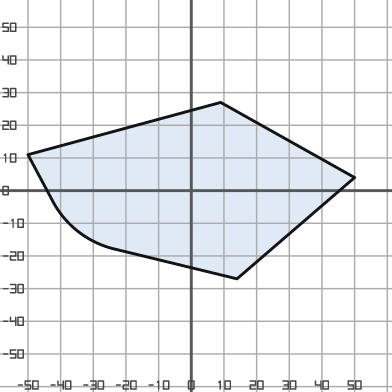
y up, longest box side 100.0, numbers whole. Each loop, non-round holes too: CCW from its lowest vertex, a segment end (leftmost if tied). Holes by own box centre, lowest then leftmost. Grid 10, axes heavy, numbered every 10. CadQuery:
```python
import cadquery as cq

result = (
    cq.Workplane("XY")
    .moveTo(14.0, -27.0)
    .lineTo(50.0, 4.0)
    .lineTo(9.0, 27.0)
    .lineTo(-50.0, 11.0)
    .lineTo(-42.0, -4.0)
    .threePointArc((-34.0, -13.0), (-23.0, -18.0))
    .close()
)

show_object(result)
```